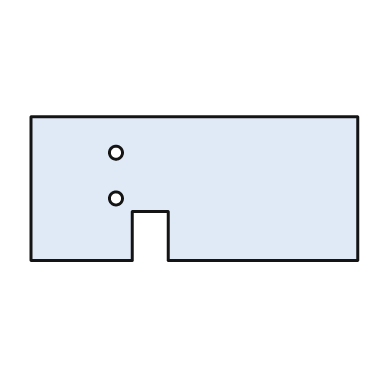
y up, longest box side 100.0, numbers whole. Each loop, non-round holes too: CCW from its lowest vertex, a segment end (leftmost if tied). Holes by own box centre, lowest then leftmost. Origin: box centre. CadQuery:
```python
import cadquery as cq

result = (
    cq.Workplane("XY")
    .moveTo(-50.0, -22.0)
    .lineTo(-19.0, -22.0)
    .lineTo(-19.0, -7.0)
    .lineTo(-8.0, -7.0)
    .lineTo(-8.0, -22.0)
    .lineTo(50.0, -22.0)
    .lineTo(50.0, 22.0)
    .lineTo(-50.0, 22.0)
    .close()
    .moveTo(-24.0, -3.0)
    .circle(2.0)
    .moveTo(-24.0, 11.0)
    .circle(2.0)
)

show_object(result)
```